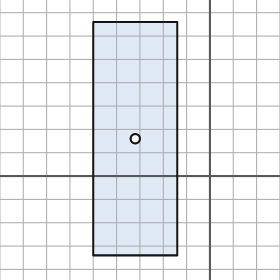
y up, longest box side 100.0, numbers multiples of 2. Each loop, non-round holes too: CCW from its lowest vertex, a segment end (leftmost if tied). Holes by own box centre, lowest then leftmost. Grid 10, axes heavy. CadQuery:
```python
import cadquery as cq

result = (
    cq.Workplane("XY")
    .moveTo(-50.0, -34.0)
    .lineTo(-14.0, -34.0)
    .lineTo(-14.0, 66.0)
    .lineTo(-50.0, 66.0)
    .close()
    .moveTo(-32.0, 16.0)
    .circle(2.0)
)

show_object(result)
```